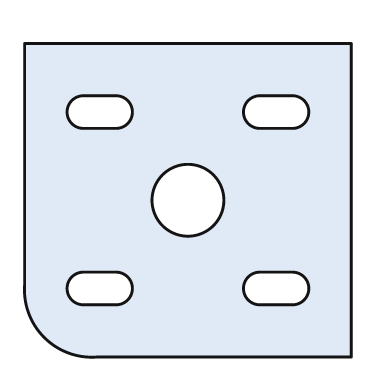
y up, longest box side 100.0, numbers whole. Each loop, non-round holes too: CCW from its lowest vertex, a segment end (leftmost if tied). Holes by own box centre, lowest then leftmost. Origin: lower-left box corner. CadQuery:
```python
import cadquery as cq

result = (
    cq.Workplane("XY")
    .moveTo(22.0, 0.0)
    .lineTo(100.0, 0.0)
    .lineTo(100.0, 96.0)
    .lineTo(0.0, 96.0)
    .lineTo(0.0, 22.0)
    .threePointArc((6.0, 6.0), (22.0, 0.0))
    .close()
    .moveTo(18.0, 16.0)
    .lineTo(28.0, 16.0)
    .threePointArc((33.0, 21.0), (28.0, 26.0))
    .lineTo(18.0, 26.0)
    .threePointArc((13.0, 21.0), (18.0, 16.0))
    .close()
    .moveTo(72.0, 16.0)
    .lineTo(82.0, 16.0)
    .threePointArc((87.0, 21.0), (82.0, 26.0))
    .lineTo(72.0, 26.0)
    .threePointArc((67.0, 21.0), (72.0, 16.0))
    .close()
    .moveTo(50.0, 48.0)
    .circle(11.0)
    .moveTo(18.0, 70.0)
    .lineTo(28.0, 70.0)
    .threePointArc((33.0, 75.0), (28.0, 80.0))
    .lineTo(18.0, 80.0)
    .threePointArc((13.0, 75.0), (18.0, 70.0))
    .close()
    .moveTo(72.0, 70.0)
    .lineTo(82.0, 70.0)
    .threePointArc((87.0, 75.0), (82.0, 80.0))
    .lineTo(72.0, 80.0)
    .threePointArc((67.0, 75.0), (72.0, 70.0))
    .close()
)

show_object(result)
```